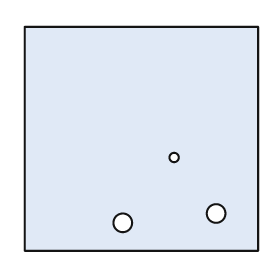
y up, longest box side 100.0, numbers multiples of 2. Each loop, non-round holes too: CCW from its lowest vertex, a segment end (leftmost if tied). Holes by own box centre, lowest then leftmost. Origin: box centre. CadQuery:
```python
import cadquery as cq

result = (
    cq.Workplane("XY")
    .moveTo(-50.0, -48.0)
    .lineTo(50.0, -48.0)
    .lineTo(50.0, 48.0)
    .lineTo(-50.0, 48.0)
    .close()
    .moveTo(-8.0, -36.0)
    .circle(4.0)
    .moveTo(32.0, -32.0)
    .circle(4.0)
    .moveTo(14.0, -8.0)
    .circle(2.0)
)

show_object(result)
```